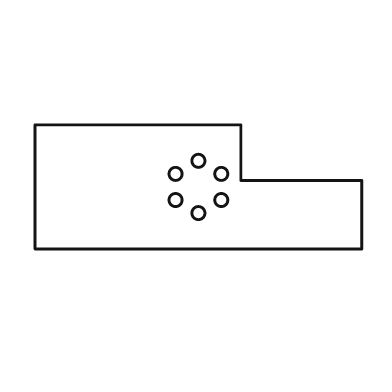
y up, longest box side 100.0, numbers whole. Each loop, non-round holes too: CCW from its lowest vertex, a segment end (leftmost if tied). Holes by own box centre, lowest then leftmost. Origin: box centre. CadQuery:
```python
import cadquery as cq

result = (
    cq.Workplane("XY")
    .moveTo(-50.0, -19.0)
    .lineTo(50.0, -19.0)
    .lineTo(50.0, 2.0)
    .lineTo(13.0, 2.0)
    .lineTo(13.0, 19.0)
    .lineTo(-50.0, 19.0)
    .close()
    .moveTo(0.0, -8.0)
    .circle(2.0)
    .moveTo(-7.0, -4.0)
    .circle(2.0)
    .moveTo(7.0, -4.0)
    .circle(2.0)
    .moveTo(-7.0, 4.0)
    .circle(2.0)
    .moveTo(7.0, 4.0)
    .circle(2.0)
    .moveTo(0.0, 8.0)
    .circle(2.0)
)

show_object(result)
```